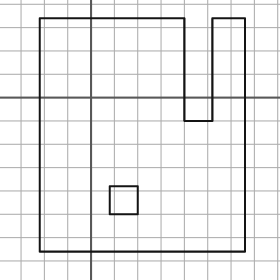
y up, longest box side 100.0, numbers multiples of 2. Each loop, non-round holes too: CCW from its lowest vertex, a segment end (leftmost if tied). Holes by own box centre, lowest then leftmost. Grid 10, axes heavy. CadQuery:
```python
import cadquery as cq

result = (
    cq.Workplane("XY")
    .moveTo(-22.0, -66.0)
    .lineTo(66.0, -66.0)
    .lineTo(66.0, 34.0)
    .lineTo(52.0, 34.0)
    .lineTo(52.0, -10.0)
    .lineTo(40.0, -10.0)
    .lineTo(40.0, 34.0)
    .lineTo(-22.0, 34.0)
    .close()
    .moveTo(8.0, -50.0)
    .lineTo(20.0, -50.0)
    .lineTo(20.0, -38.0)
    .lineTo(8.0, -38.0)
    .close()
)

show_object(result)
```